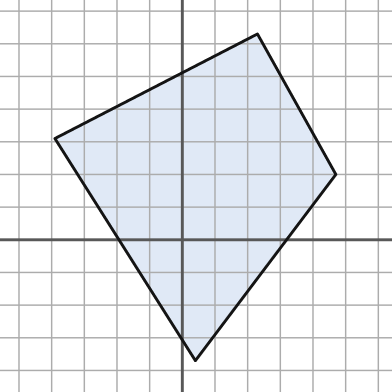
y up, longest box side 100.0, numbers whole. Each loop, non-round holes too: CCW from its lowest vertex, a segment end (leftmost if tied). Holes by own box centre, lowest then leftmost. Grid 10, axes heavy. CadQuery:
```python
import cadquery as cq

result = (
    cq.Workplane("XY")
    .moveTo(4.0, -37.0)
    .lineTo(47.0, 20.0)
    .lineTo(23.0, 63.0)
    .lineTo(-39.0, 31.0)
    .close()
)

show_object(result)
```